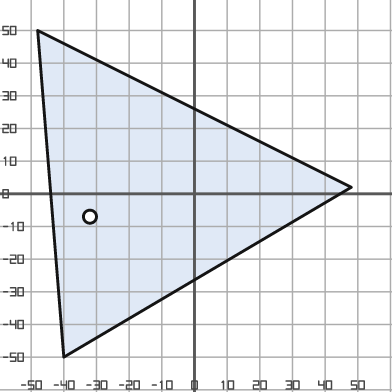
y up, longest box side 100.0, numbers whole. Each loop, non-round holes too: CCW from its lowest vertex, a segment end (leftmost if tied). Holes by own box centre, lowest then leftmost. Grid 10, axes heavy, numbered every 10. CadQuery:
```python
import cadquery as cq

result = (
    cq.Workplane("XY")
    .moveTo(-40.0, -50.0)
    .lineTo(48.0, 2.0)
    .lineTo(-48.0, 50.0)
    .close()
    .moveTo(-32.0, -7.0)
    .circle(2.0)
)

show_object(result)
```